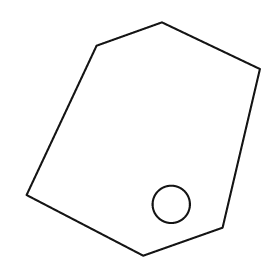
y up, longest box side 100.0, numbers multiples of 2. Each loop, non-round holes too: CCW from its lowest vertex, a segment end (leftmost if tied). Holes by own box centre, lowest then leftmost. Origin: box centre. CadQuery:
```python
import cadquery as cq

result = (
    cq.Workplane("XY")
    .moveTo(0.0, -50.0)
    .lineTo(34.0, -38.0)
    .lineTo(50.0, 30.0)
    .lineTo(8.0, 50.0)
    .lineTo(-20.0, 40.0)
    .lineTo(-50.0, -24.0)
    .close()
    .moveTo(12.0, -28.0)
    .circle(8.0)
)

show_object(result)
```